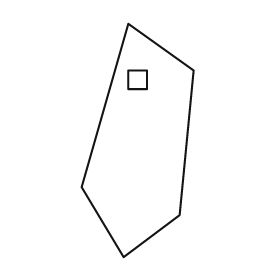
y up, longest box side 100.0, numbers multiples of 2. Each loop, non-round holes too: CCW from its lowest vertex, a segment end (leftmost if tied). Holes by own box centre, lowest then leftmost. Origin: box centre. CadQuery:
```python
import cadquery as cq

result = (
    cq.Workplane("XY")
    .moveTo(-6.0, -50.0)
    .lineTo(18.0, -32.0)
    .lineTo(24.0, 30.0)
    .lineTo(-4.0, 50.0)
    .lineTo(-24.0, -20.0)
    .close()
    .moveTo(-4.0, 22.0)
    .lineTo(4.0, 22.0)
    .lineTo(4.0, 30.0)
    .lineTo(-4.0, 30.0)
    .close()
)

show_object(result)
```